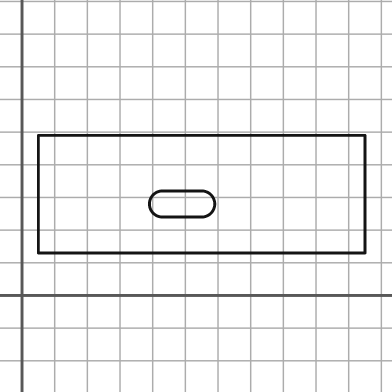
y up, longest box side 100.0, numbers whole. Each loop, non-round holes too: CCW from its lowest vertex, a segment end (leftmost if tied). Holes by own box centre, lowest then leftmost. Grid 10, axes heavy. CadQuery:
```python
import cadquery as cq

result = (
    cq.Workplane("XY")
    .moveTo(5.0, 13.0)
    .lineTo(105.0, 13.0)
    .lineTo(105.0, 49.0)
    .lineTo(5.0, 49.0)
    .close()
    .moveTo(43.0, 24.0)
    .lineTo(55.0, 24.0)
    .threePointArc((59.0, 28.0), (55.0, 32.0))
    .lineTo(43.0, 32.0)
    .threePointArc((39.0, 28.0), (43.0, 24.0))
    .close()
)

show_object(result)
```